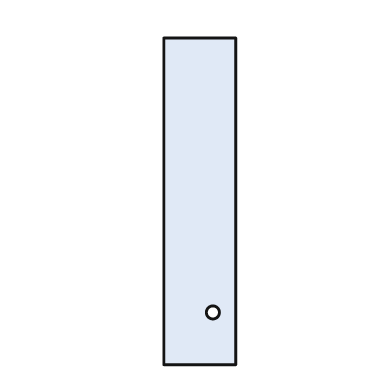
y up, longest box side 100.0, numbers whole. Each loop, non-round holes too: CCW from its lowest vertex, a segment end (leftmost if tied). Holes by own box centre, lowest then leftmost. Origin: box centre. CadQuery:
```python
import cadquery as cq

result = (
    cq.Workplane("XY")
    .moveTo(-11.0, -50.0)
    .lineTo(11.0, -50.0)
    .lineTo(11.0, 50.0)
    .lineTo(-11.0, 50.0)
    .close()
    .moveTo(4.0, -34.0)
    .circle(2.0)
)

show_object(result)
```